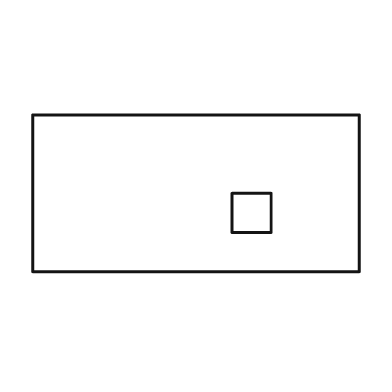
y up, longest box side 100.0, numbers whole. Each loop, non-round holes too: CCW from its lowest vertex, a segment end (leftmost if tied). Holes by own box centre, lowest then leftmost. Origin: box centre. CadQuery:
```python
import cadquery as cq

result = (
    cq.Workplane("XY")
    .moveTo(-50.0, -24.0)
    .lineTo(50.0, -24.0)
    .lineTo(50.0, 24.0)
    .lineTo(-50.0, 24.0)
    .close()
    .moveTo(11.0, -12.0)
    .lineTo(23.0, -12.0)
    .lineTo(23.0, 0.0)
    .lineTo(11.0, 0.0)
    .close()
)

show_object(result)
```